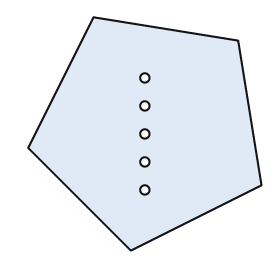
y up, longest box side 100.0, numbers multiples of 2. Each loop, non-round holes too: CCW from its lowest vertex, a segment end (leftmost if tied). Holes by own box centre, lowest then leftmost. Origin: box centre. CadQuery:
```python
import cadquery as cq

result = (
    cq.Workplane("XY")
    .moveTo(-6.0, -50.0)
    .lineTo(50.0, -22.0)
    .lineTo(40.0, 40.0)
    .lineTo(-22.0, 50.0)
    .lineTo(-50.0, -6.0)
    .close()
    .moveTo(0.0, -24.0)
    .circle(2.0)
    .moveTo(0.0, -12.0)
    .circle(2.0)
    .moveTo(0.0, 0.0)
    .circle(2.0)
    .moveTo(0.0, 12.0)
    .circle(2.0)
    .moveTo(0.0, 24.0)
    .circle(2.0)
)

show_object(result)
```